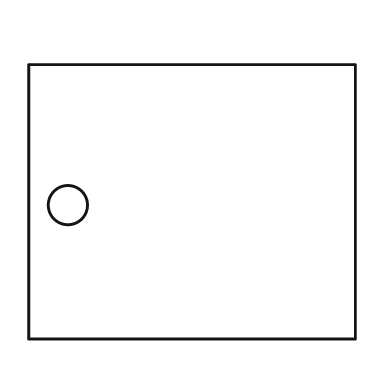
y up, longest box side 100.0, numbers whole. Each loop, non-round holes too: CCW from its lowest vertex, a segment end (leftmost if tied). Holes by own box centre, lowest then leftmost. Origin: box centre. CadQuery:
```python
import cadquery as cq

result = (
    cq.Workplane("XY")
    .moveTo(-50.0, -42.0)
    .lineTo(50.0, -42.0)
    .lineTo(50.0, 42.0)
    .lineTo(-50.0, 42.0)
    .close()
    .moveTo(-38.0, -1.0)
    .circle(6.0)
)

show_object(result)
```